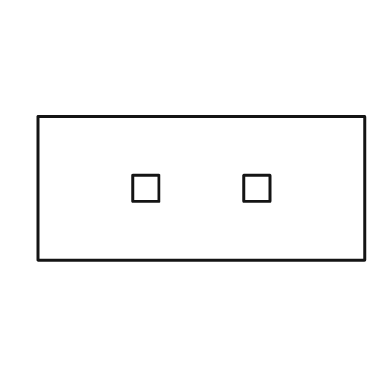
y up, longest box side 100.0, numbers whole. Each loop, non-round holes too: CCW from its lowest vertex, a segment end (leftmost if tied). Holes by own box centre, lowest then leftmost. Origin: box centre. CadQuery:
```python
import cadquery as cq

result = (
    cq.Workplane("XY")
    .moveTo(-50.0, -22.0)
    .lineTo(50.0, -22.0)
    .lineTo(50.0, 22.0)
    .lineTo(-50.0, 22.0)
    .close()
    .moveTo(-21.0, -4.0)
    .lineTo(-13.0, -4.0)
    .lineTo(-13.0, 4.0)
    .lineTo(-21.0, 4.0)
    .close()
    .moveTo(13.0, -4.0)
    .lineTo(21.0, -4.0)
    .lineTo(21.0, 4.0)
    .lineTo(13.0, 4.0)
    .close()
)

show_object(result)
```